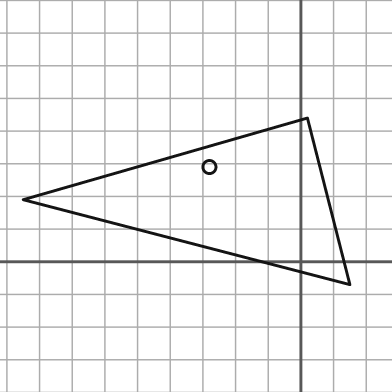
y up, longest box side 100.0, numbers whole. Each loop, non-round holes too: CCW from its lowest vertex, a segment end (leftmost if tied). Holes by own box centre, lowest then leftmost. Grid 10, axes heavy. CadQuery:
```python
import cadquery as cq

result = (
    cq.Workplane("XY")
    .moveTo(15.0, -7.0)
    .lineTo(2.0, 44.0)
    .lineTo(-85.0, 19.0)
    .close()
    .moveTo(-28.0, 29.0)
    .circle(2.0)
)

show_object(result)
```